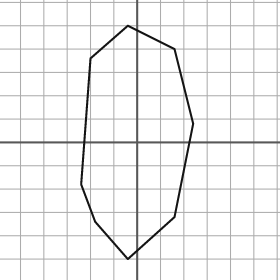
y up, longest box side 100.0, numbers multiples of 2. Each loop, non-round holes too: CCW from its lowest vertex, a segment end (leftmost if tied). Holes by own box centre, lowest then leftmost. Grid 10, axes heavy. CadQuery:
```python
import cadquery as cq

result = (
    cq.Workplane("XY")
    .moveTo(-4.0, -50.0)
    .lineTo(16.0, -32.0)
    .lineTo(24.0, 8.0)
    .lineTo(16.0, 40.0)
    .lineTo(-4.0, 50.0)
    .lineTo(-20.0, 36.0)
    .lineTo(-24.0, -18.0)
    .lineTo(-18.0, -34.0)
    .close()
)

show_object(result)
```